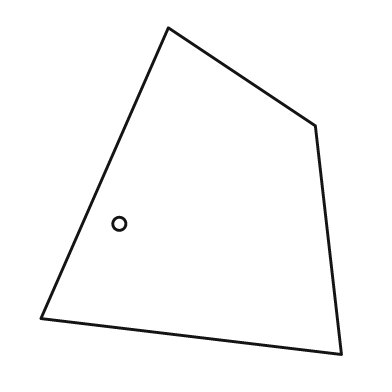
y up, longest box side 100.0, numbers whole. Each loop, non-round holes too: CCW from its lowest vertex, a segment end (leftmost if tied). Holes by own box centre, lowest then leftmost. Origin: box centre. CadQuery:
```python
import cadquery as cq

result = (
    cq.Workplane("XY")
    .moveTo(46.0, -50.0)
    .lineTo(38.0, 20.0)
    .lineTo(-7.0, 50.0)
    .lineTo(-46.0, -39.0)
    .close()
    .moveTo(-22.0, -10.0)
    .circle(2.0)
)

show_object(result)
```